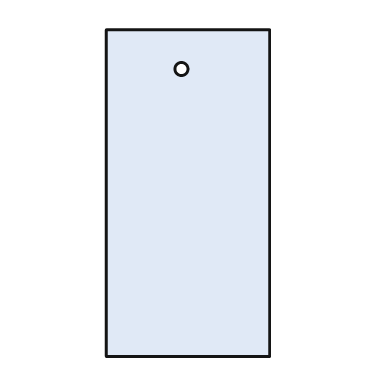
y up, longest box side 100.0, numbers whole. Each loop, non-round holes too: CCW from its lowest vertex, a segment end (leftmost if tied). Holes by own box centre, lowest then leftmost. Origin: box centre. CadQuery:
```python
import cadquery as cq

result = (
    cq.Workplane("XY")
    .moveTo(-25.0, -50.0)
    .lineTo(25.0, -50.0)
    .lineTo(25.0, 50.0)
    .lineTo(-25.0, 50.0)
    .close()
    .moveTo(-2.0, 38.0)
    .circle(2.0)
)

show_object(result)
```